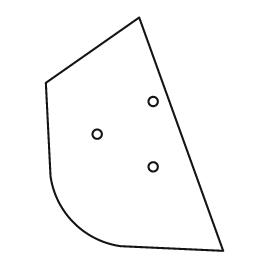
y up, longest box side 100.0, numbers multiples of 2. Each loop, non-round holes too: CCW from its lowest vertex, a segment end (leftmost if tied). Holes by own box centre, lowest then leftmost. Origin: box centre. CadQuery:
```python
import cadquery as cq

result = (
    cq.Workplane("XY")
    .moveTo(38.0, -50.0)
    .lineTo(2.0, 50.0)
    .lineTo(-38.0, 22.0)
    .lineTo(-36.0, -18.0)
    .threePointArc((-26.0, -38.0), (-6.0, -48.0))
    .close()
    .moveTo(8.0, -14.0)
    .circle(2.0)
    .moveTo(-16.0, 0.0)
    .circle(2.0)
    .moveTo(8.0, 14.0)
    .circle(2.0)
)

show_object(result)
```